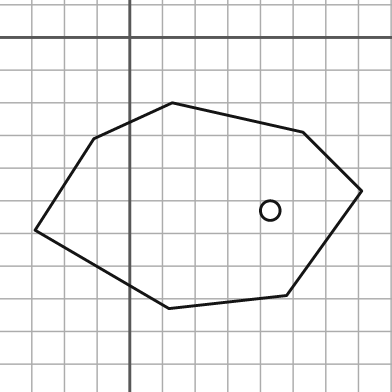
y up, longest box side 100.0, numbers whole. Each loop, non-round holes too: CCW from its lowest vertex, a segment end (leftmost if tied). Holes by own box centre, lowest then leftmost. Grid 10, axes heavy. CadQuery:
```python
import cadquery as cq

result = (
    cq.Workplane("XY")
    .moveTo(12.0, -83.0)
    .lineTo(48.0, -79.0)
    .lineTo(71.0, -47.0)
    .lineTo(53.0, -29.0)
    .lineTo(13.0, -20.0)
    .lineTo(-11.0, -31.0)
    .lineTo(-29.0, -59.0)
    .close()
    .moveTo(43.0, -53.0)
    .circle(3.0)
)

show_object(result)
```